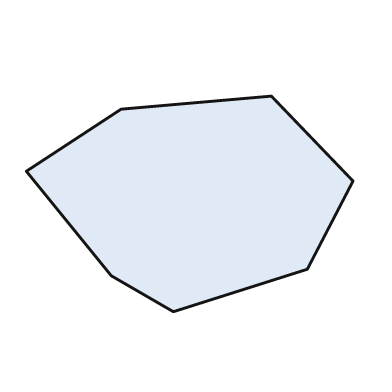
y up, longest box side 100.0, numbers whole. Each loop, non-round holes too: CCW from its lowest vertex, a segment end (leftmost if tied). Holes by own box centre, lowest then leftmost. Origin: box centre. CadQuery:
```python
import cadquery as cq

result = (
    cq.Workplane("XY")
    .moveTo(-5.0, -33.0)
    .lineTo(36.0, -20.0)
    .lineTo(50.0, 7.0)
    .lineTo(25.0, 33.0)
    .lineTo(-21.0, 29.0)
    .lineTo(-50.0, 10.0)
    .lineTo(-24.0, -22.0)
    .close()
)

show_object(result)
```